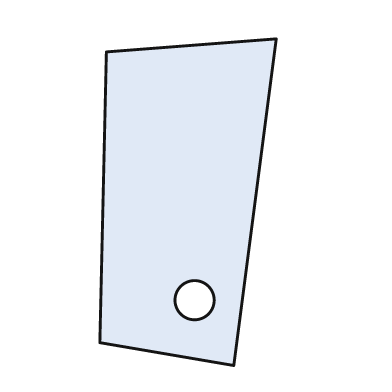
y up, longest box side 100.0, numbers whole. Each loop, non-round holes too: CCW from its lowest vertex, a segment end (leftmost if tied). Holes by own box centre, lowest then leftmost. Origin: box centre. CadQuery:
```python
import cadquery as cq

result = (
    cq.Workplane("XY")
    .moveTo(14.0, -50.0)
    .lineTo(27.0, 50.0)
    .lineTo(-25.0, 46.0)
    .lineTo(-27.0, -43.0)
    .close()
    .moveTo(2.0, -30.0)
    .circle(6.0)
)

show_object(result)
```